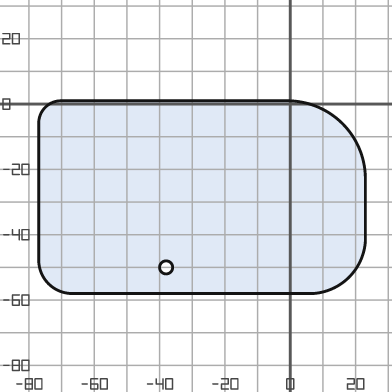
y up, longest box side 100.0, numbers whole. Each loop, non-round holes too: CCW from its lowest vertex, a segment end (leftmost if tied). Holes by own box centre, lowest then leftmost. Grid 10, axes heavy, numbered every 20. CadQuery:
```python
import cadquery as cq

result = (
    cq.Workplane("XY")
    .moveTo(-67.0, -58.0)
    .lineTo(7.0, -58.0)
    .threePointArc((18.0, -53.0), (23.0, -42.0))
    .lineTo(23.0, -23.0)
    .threePointArc((16.0, -6.0), (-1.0, 1.0))
    .lineTo(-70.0, 1.0)
    .threePointArc((-75.0, -1.0), (-77.0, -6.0))
    .lineTo(-77.0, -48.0)
    .threePointArc((-74.0, -55.0), (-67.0, -58.0))
    .close()
    .moveTo(-38.0, -50.0)
    .circle(2.0)
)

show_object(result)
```